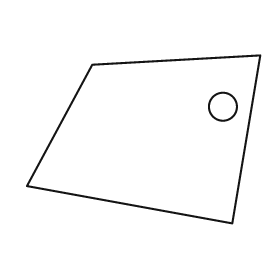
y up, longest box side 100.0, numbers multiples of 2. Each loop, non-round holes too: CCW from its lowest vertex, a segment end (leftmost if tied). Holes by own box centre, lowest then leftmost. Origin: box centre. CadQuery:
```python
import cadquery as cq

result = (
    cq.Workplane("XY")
    .moveTo(38.0, -36.0)
    .lineTo(50.0, 36.0)
    .lineTo(-22.0, 32.0)
    .lineTo(-50.0, -20.0)
    .close()
    .moveTo(34.0, 14.0)
    .circle(6.0)
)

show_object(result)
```